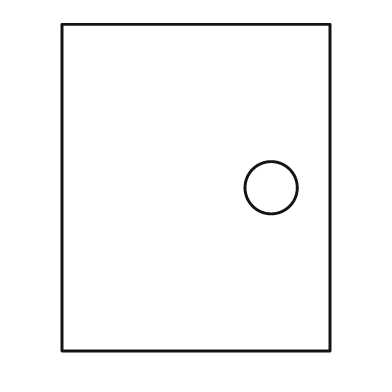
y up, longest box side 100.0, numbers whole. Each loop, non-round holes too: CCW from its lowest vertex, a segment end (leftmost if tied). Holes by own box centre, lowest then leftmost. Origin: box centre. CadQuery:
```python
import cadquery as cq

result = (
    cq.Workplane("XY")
    .moveTo(-41.0, -50.0)
    .lineTo(41.0, -50.0)
    .lineTo(41.0, 50.0)
    .lineTo(-41.0, 50.0)
    .close()
    .moveTo(23.0, 0.0)
    .circle(8.0)
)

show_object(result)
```